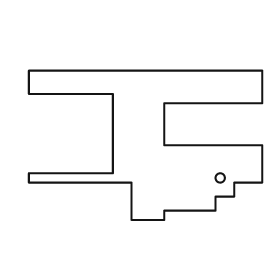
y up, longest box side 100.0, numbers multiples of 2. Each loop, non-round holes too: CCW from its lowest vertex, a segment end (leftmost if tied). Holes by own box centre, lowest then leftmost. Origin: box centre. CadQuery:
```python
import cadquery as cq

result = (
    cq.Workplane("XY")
    .moveTo(-6.0, -32.0)
    .lineTo(8.0, -32.0)
    .lineTo(8.0, -28.0)
    .lineTo(30.0, -28.0)
    .lineTo(30.0, -22.0)
    .lineTo(38.0, -22.0)
    .lineTo(38.0, -16.0)
    .lineTo(50.0, -16.0)
    .lineTo(50.0, 0.0)
    .lineTo(8.0, 0.0)
    .lineTo(8.0, 18.0)
    .lineTo(50.0, 18.0)
    .lineTo(50.0, 32.0)
    .lineTo(-50.0, 32.0)
    .lineTo(-50.0, 22.0)
    .lineTo(-14.0, 22.0)
    .lineTo(-14.0, -12.0)
    .lineTo(-50.0, -12.0)
    .lineTo(-50.0, -16.0)
    .lineTo(-6.0, -16.0)
    .close()
    .moveTo(32.0, -14.0)
    .circle(2.0)
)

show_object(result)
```